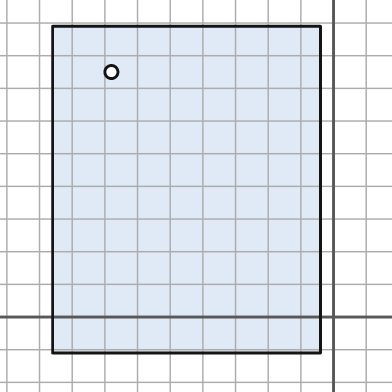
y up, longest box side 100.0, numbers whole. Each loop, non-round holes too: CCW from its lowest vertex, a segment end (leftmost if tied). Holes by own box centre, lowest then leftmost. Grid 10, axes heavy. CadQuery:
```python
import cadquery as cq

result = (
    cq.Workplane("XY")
    .moveTo(-86.0, -11.0)
    .lineTo(-4.0, -11.0)
    .lineTo(-4.0, 89.0)
    .lineTo(-86.0, 89.0)
    .close()
    .moveTo(-68.0, 75.0)
    .circle(2.0)
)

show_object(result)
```